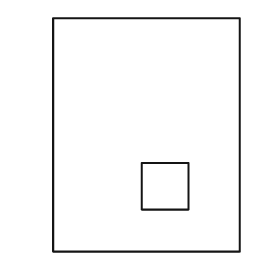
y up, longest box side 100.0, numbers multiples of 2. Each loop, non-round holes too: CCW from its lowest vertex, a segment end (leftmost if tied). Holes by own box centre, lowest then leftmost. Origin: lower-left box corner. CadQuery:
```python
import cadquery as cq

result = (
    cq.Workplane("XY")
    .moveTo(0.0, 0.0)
    .lineTo(80.0, 0.0)
    .lineTo(80.0, 100.0)
    .lineTo(0.0, 100.0)
    .close()
    .moveTo(38.0, 18.0)
    .lineTo(58.0, 18.0)
    .lineTo(58.0, 38.0)
    .lineTo(38.0, 38.0)
    .close()
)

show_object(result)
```